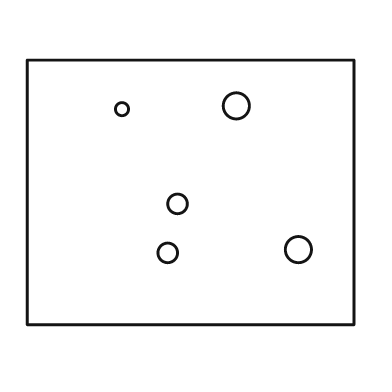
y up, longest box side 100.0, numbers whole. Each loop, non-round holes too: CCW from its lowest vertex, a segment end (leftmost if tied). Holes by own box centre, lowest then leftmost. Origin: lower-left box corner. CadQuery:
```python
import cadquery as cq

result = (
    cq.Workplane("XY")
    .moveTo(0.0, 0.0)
    .lineTo(100.0, 0.0)
    .lineTo(100.0, 81.0)
    .lineTo(0.0, 81.0)
    .close()
    .moveTo(43.0, 22.0)
    .circle(3.0)
    .moveTo(83.0, 23.0)
    .circle(4.0)
    .moveTo(46.0, 37.0)
    .circle(3.0)
    .moveTo(29.0, 66.0)
    .circle(2.0)
    .moveTo(64.0, 67.0)
    .circle(4.0)
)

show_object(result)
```